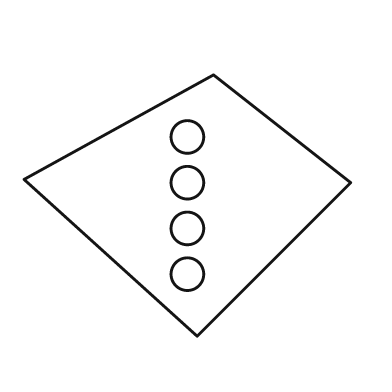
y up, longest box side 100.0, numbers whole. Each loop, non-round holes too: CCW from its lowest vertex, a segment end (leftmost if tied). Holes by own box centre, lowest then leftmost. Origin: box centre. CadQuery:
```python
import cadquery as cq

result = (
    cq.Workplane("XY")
    .moveTo(3.0, -40.0)
    .lineTo(50.0, 7.0)
    .lineTo(8.0, 40.0)
    .lineTo(-50.0, 8.0)
    .close()
    .moveTo(0.0, -21.0)
    .circle(5.0)
    .moveTo(0.0, -7.0)
    .circle(5.0)
    .moveTo(0.0, 7.0)
    .circle(5.0)
    .moveTo(0.0, 21.0)
    .circle(5.0)
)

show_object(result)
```